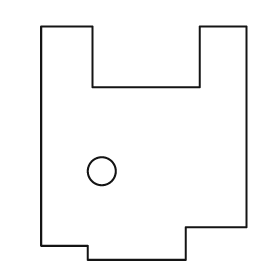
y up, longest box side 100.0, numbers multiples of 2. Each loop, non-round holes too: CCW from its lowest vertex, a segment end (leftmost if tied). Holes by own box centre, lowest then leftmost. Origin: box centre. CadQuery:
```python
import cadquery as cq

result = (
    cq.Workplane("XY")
    .moveTo(-24.0, -50.0)
    .lineTo(18.0, -50.0)
    .lineTo(18.0, -36.0)
    .lineTo(44.0, -36.0)
    .lineTo(44.0, 50.0)
    .lineTo(24.0, 50.0)
    .lineTo(24.0, 24.0)
    .lineTo(-22.0, 24.0)
    .lineTo(-22.0, 50.0)
    .lineTo(-44.0, 50.0)
    .lineTo(-44.0, -44.0)
    .lineTo(-24.0, -44.0)
    .close()
    .moveTo(-18.0, -12.0)
    .circle(6.0)
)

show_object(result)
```